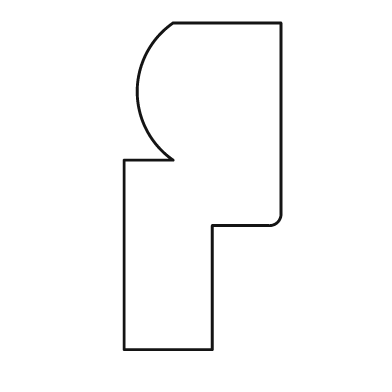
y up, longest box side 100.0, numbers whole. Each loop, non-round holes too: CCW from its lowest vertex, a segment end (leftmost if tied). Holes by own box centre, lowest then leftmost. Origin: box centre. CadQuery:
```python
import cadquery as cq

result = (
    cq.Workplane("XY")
    .moveTo(-24.0, -50.0)
    .lineTo(3.0, -50.0)
    .lineTo(3.0, -12.0)
    .lineTo(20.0, -12.0)
    .threePointArc((23.0, -11.0), (24.0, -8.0))
    .lineTo(24.0, 50.0)
    .lineTo(-9.0, 50.0)
    .threePointArc((-20.0, 29.0), (-9.0, 8.0))
    .lineTo(-24.0, 8.0)
    .close()
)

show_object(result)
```